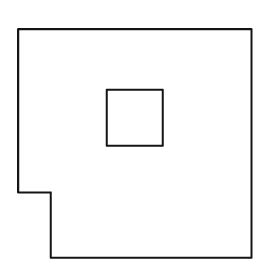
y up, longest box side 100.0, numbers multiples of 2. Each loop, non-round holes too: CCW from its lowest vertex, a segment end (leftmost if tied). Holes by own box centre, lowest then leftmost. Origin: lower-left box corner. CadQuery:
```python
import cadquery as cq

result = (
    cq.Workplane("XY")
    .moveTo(14.0, 0.0)
    .lineTo(100.0, 0.0)
    .lineTo(100.0, 98.0)
    .lineTo(0.0, 98.0)
    .lineTo(0.0, 28.0)
    .lineTo(14.0, 28.0)
    .close()
    .moveTo(38.0, 48.0)
    .lineTo(62.0, 48.0)
    .lineTo(62.0, 72.0)
    .lineTo(38.0, 72.0)
    .close()
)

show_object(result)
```